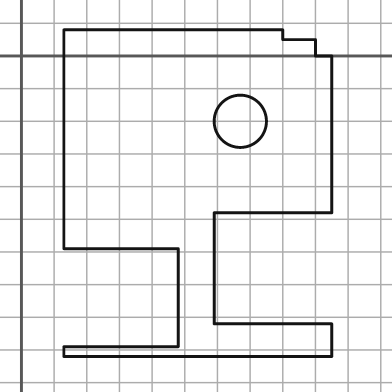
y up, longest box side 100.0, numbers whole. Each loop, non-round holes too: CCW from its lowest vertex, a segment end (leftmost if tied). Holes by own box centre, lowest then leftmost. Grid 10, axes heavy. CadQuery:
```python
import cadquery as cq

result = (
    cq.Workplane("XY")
    .moveTo(13.0, -92.0)
    .lineTo(95.0, -92.0)
    .lineTo(95.0, -82.0)
    .lineTo(59.0, -82.0)
    .lineTo(59.0, -48.0)
    .lineTo(95.0, -48.0)
    .lineTo(95.0, 0.0)
    .lineTo(90.0, 0.0)
    .lineTo(90.0, 5.0)
    .lineTo(80.0, 5.0)
    .lineTo(80.0, 8.0)
    .lineTo(13.0, 8.0)
    .lineTo(13.0, -59.0)
    .lineTo(48.0, -59.0)
    .lineTo(48.0, -89.0)
    .lineTo(13.0, -89.0)
    .close()
    .moveTo(67.0, -20.0)
    .circle(8.0)
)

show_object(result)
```